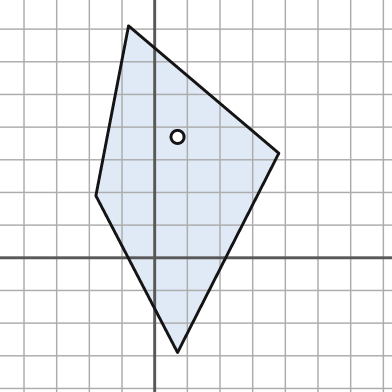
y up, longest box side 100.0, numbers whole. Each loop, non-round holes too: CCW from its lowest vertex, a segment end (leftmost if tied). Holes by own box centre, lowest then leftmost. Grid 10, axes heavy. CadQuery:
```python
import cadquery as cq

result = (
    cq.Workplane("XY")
    .moveTo(7.0, -29.0)
    .lineTo(38.0, 32.0)
    .lineTo(-8.0, 71.0)
    .lineTo(-18.0, 19.0)
    .close()
    .moveTo(7.0, 37.0)
    .circle(2.0)
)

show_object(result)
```